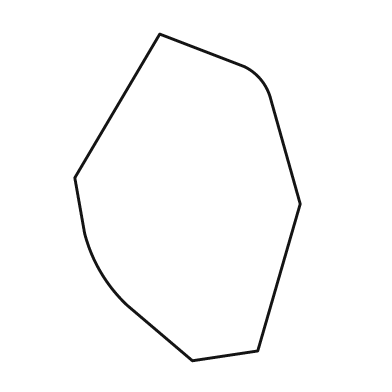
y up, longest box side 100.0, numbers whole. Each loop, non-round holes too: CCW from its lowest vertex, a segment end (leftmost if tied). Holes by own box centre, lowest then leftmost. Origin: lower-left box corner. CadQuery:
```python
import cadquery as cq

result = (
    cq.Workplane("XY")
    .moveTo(36.0, 0.0)
    .lineTo(56.0, 3.0)
    .lineTo(69.0, 48.0)
    .lineTo(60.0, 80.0)
    .threePointArc((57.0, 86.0), (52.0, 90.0))
    .lineTo(26.0, 100.0)
    .lineTo(0.0, 56.0)
    .lineTo(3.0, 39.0)
    .threePointArc((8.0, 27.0), (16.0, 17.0))
    .close()
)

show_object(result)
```